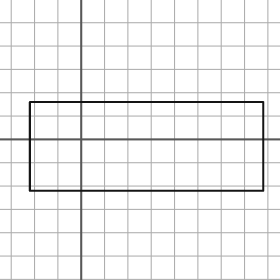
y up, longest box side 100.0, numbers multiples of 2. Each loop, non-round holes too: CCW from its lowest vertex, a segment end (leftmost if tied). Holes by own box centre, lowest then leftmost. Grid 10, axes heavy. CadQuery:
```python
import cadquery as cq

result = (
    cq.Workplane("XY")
    .moveTo(-22.0, -22.0)
    .lineTo(78.0, -22.0)
    .lineTo(78.0, 16.0)
    .lineTo(-22.0, 16.0)
    .close()
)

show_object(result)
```